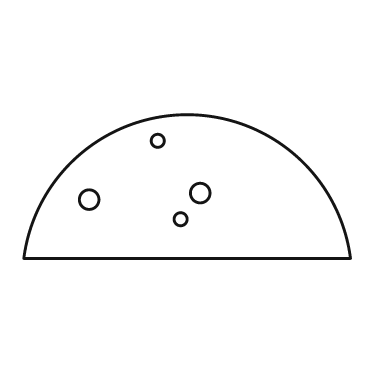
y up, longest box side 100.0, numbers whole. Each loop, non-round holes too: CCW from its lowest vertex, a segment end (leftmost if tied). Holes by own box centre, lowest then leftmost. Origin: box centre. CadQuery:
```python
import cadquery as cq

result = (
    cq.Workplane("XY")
    .moveTo(-50.0, -22.0)
    .lineTo(50.0, -22.0)
    .threePointArc((0.0, 22.0), (-50.0, -22.0))
    .close()
    .moveTo(-2.0, -10.0)
    .circle(2.0)
    .moveTo(-30.0, -4.0)
    .circle(3.0)
    .moveTo(4.0, -2.0)
    .circle(3.0)
    .moveTo(-9.0, 14.0)
    .circle(2.0)
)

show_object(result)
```